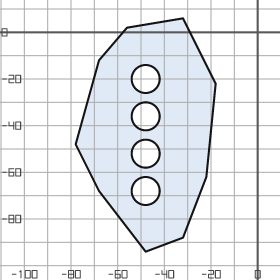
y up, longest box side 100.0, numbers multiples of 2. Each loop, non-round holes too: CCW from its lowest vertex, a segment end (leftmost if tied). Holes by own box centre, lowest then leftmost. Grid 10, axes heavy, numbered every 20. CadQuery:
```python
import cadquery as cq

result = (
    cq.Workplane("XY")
    .moveTo(-48.0, -94.0)
    .lineTo(-32.0, -88.0)
    .lineTo(-22.0, -62.0)
    .lineTo(-18.0, -22.0)
    .lineTo(-32.0, 6.0)
    .lineTo(-56.0, 2.0)
    .lineTo(-68.0, -12.0)
    .lineTo(-78.0, -48.0)
    .lineTo(-68.0, -68.0)
    .close()
    .moveTo(-48.0, -68.0)
    .circle(6.0)
    .moveTo(-48.0, -52.0)
    .circle(6.0)
    .moveTo(-48.0, -36.0)
    .circle(6.0)
    .moveTo(-48.0, -20.0)
    .circle(6.0)
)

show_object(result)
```